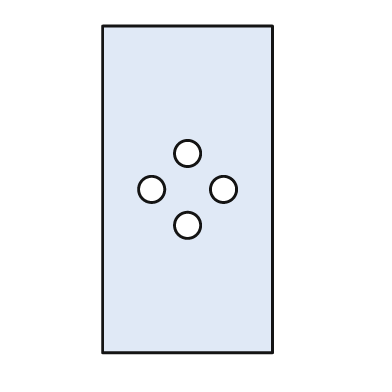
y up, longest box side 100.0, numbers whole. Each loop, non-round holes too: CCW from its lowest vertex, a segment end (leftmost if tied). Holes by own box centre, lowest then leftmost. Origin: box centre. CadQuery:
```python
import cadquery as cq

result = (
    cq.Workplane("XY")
    .moveTo(-26.0, -50.0)
    .lineTo(26.0, -50.0)
    .lineTo(26.0, 50.0)
    .lineTo(-26.0, 50.0)
    .close()
    .moveTo(0.0, -11.0)
    .circle(4.0)
    .moveTo(-11.0, 0.0)
    .circle(4.0)
    .moveTo(11.0, 0.0)
    .circle(4.0)
    .moveTo(0.0, 11.0)
    .circle(4.0)
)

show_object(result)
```